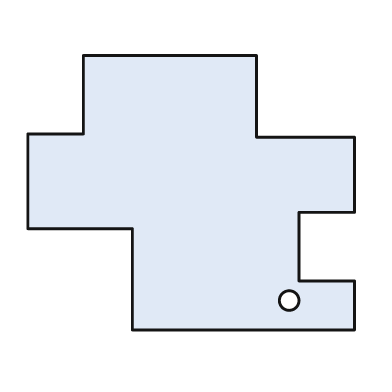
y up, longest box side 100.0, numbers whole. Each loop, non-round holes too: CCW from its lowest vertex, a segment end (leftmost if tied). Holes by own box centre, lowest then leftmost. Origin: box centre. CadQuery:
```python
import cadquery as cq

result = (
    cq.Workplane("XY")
    .moveTo(-18.0, -42.0)
    .lineTo(50.0, -42.0)
    .lineTo(50.0, -27.0)
    .lineTo(33.0, -27.0)
    .lineTo(33.0, -6.0)
    .lineTo(50.0, -6.0)
    .lineTo(50.0, 17.0)
    .lineTo(20.0, 17.0)
    .lineTo(20.0, 42.0)
    .lineTo(-33.0, 42.0)
    .lineTo(-33.0, 18.0)
    .lineTo(-50.0, 18.0)
    .lineTo(-50.0, -11.0)
    .lineTo(-18.0, -11.0)
    .close()
    .moveTo(30.0, -33.0)
    .circle(3.0)
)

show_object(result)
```